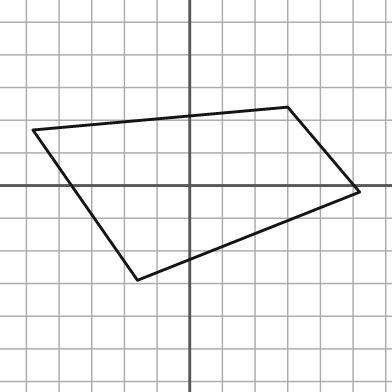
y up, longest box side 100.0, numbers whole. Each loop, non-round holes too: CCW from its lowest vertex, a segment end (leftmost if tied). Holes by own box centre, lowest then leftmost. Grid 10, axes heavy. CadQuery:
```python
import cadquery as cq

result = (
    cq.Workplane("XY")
    .moveTo(-16.0, -29.0)
    .lineTo(52.0, -2.0)
    .lineTo(30.0, 24.0)
    .lineTo(-48.0, 17.0)
    .close()
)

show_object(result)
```